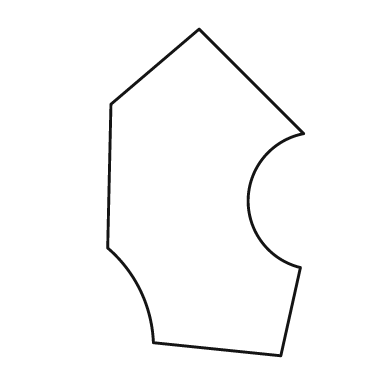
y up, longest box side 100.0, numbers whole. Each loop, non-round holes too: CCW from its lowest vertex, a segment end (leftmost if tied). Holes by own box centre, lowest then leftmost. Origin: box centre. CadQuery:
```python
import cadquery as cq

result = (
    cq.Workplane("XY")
    .moveTo(23.0, -50.0)
    .lineTo(29.0, -23.0)
    .threePointArc((13.0, -2.0), (30.0, 18.0))
    .lineTo(-2.0, 50.0)
    .lineTo(-29.0, 27.0)
    .lineTo(-30.0, -17.0)
    .threePointArc((-20.0, -30.0), (-16.0, -46.0))
    .close()
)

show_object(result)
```